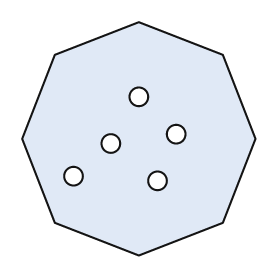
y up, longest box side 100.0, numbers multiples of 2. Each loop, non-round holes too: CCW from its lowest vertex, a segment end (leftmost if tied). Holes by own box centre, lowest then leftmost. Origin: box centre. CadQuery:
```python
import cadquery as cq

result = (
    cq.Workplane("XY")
    .moveTo(0.0, -50.0)
    .lineTo(36.0, -36.0)
    .lineTo(50.0, 0.0)
    .lineTo(36.0, 36.0)
    .lineTo(0.0, 50.0)
    .lineTo(-36.0, 36.0)
    .lineTo(-50.0, 0.0)
    .lineTo(-36.0, -36.0)
    .close()
    .moveTo(8.0, -18.0)
    .circle(4.0)
    .moveTo(-28.0, -16.0)
    .circle(4.0)
    .moveTo(-12.0, -2.0)
    .circle(4.0)
    .moveTo(16.0, 2.0)
    .circle(4.0)
    .moveTo(0.0, 18.0)
    .circle(4.0)
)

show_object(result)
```